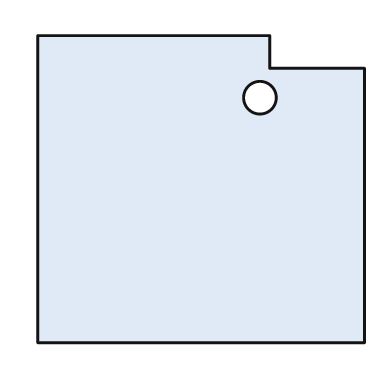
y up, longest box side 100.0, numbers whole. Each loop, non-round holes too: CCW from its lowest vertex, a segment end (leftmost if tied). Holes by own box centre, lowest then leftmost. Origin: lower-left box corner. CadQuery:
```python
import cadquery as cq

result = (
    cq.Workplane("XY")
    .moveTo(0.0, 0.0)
    .lineTo(100.0, 0.0)
    .lineTo(100.0, 84.0)
    .lineTo(71.0, 84.0)
    .lineTo(71.0, 94.0)
    .lineTo(0.0, 94.0)
    .close()
    .moveTo(68.0, 75.0)
    .circle(5.0)
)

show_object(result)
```